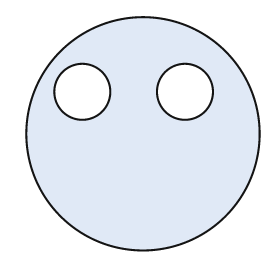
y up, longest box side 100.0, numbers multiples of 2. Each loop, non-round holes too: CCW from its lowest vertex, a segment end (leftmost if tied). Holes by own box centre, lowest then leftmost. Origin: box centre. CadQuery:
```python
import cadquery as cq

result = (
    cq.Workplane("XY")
    .moveTo(0.0, 0.0)
    .circle(50.0)
    .moveTo(-26.0, 18.0)
    .circle(12.0)
    .moveTo(18.0, 18.0)
    .circle(12.0)
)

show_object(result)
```